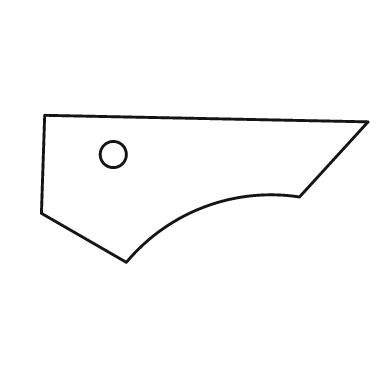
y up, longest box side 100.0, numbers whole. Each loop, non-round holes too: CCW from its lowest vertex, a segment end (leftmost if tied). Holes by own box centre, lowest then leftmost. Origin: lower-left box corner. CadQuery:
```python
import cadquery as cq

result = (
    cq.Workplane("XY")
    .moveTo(26.0, 0.0)
    .threePointArc((50.0, 17.0), (79.0, 20.0))
    .lineTo(100.0, 43.0)
    .lineTo(1.0, 45.0)
    .lineTo(0.0, 15.0)
    .close()
    .moveTo(22.0, 33.0)
    .circle(4.0)
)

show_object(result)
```